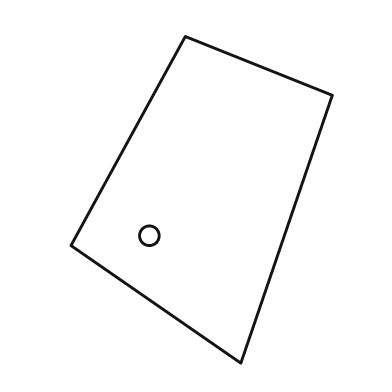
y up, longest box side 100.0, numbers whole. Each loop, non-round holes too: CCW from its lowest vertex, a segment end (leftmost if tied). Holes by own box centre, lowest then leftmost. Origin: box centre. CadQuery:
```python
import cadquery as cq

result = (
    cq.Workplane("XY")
    .moveTo(12.0, -50.0)
    .lineTo(40.0, 32.0)
    .lineTo(-5.0, 50.0)
    .lineTo(-40.0, -14.0)
    .close()
    .moveTo(-16.0, -11.0)
    .circle(3.0)
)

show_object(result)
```